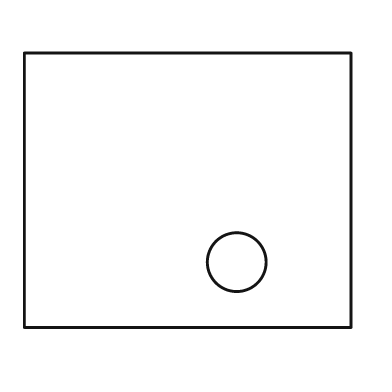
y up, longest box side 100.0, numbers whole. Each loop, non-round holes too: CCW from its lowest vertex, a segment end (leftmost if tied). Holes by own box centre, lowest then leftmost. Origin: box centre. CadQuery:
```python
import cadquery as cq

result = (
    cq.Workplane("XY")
    .moveTo(-50.0, -42.0)
    .lineTo(50.0, -42.0)
    .lineTo(50.0, 42.0)
    .lineTo(-50.0, 42.0)
    .close()
    .moveTo(15.0, -22.0)
    .circle(9.0)
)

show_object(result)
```